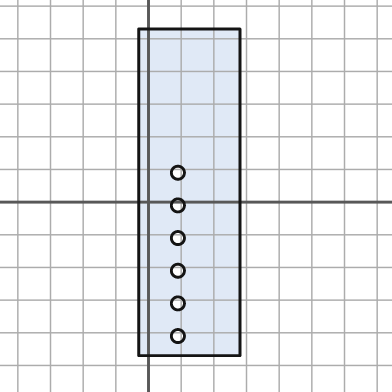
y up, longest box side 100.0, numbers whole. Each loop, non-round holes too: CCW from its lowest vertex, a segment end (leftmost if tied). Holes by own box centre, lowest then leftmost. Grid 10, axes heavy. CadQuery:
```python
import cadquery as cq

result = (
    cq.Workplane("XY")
    .moveTo(-3.0, -47.0)
    .lineTo(28.0, -47.0)
    .lineTo(28.0, 53.0)
    .lineTo(-3.0, 53.0)
    .close()
    .moveTo(9.0, -41.0)
    .circle(2.0)
    .moveTo(9.0, -31.0)
    .circle(2.0)
    .moveTo(9.0, -21.0)
    .circle(2.0)
    .moveTo(9.0, -11.0)
    .circle(2.0)
    .moveTo(9.0, -1.0)
    .circle(2.0)
    .moveTo(9.0, 9.0)
    .circle(2.0)
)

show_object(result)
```